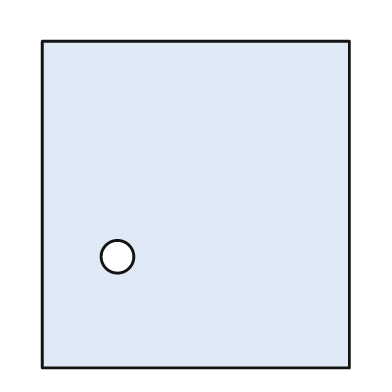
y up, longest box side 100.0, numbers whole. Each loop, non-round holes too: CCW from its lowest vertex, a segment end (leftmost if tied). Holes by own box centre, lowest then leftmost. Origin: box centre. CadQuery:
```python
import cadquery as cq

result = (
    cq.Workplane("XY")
    .moveTo(-47.0, -50.0)
    .lineTo(47.0, -50.0)
    .lineTo(47.0, 50.0)
    .lineTo(-47.0, 50.0)
    .close()
    .moveTo(-24.0, -16.0)
    .circle(5.0)
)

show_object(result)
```